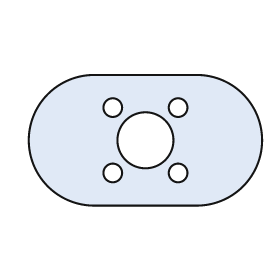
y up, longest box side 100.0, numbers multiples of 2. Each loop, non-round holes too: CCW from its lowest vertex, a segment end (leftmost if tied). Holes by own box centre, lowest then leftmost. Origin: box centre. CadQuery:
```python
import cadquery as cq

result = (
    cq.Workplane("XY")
    .moveTo(-22.0, -28.0)
    .lineTo(22.0, -28.0)
    .threePointArc((50.0, 0.0), (22.0, 28.0))
    .lineTo(-22.0, 28.0)
    .threePointArc((-50.0, 0.0), (-22.0, -28.0))
    .close()
    .moveTo(-14.0, -14.0)
    .circle(4.0)
    .moveTo(14.0, -14.0)
    .circle(4.0)
    .moveTo(0.0, 0.0)
    .circle(12.0)
    .moveTo(-14.0, 14.0)
    .circle(4.0)
    .moveTo(14.0, 14.0)
    .circle(4.0)
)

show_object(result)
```